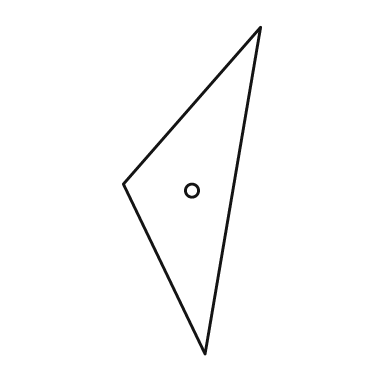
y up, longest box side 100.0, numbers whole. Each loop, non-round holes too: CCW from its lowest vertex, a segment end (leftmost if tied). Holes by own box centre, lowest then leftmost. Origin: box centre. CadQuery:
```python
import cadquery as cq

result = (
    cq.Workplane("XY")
    .moveTo(4.0, -50.0)
    .lineTo(21.0, 50.0)
    .lineTo(-21.0, 2.0)
    .close()
    .moveTo(0.0, 0.0)
    .circle(2.0)
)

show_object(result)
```